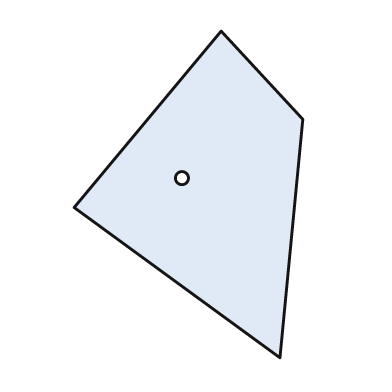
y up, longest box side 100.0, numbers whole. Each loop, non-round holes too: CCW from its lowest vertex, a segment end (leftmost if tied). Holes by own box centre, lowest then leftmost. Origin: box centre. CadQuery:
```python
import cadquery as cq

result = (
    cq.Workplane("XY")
    .moveTo(28.0, -50.0)
    .lineTo(35.0, 23.0)
    .lineTo(10.0, 50.0)
    .lineTo(-35.0, -4.0)
    .close()
    .moveTo(-2.0, 5.0)
    .circle(2.0)
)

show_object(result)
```